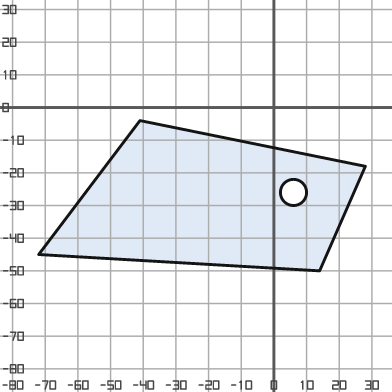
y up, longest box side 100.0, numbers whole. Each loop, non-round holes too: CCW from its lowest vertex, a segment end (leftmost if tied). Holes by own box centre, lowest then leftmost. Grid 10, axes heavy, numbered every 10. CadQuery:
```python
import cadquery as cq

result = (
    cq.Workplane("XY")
    .moveTo(14.0, -50.0)
    .lineTo(28.0, -18.0)
    .lineTo(-41.0, -4.0)
    .lineTo(-72.0, -45.0)
    .close()
    .moveTo(6.0, -26.0)
    .circle(4.0)
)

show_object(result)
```